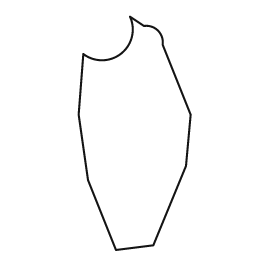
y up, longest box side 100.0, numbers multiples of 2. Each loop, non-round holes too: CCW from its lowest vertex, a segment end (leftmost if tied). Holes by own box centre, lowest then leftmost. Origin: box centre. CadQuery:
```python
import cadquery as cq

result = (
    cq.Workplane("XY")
    .moveTo(-8.0, -50.0)
    .lineTo(8.0, -48.0)
    .lineTo(22.0, -14.0)
    .lineTo(24.0, 8.0)
    .lineTo(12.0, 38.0)
    .threePointArc((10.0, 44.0), (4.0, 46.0))
    .lineTo(-2.0, 50.0)
    .threePointArc((-6.0, 34.0), (-22.0, 34.0))
    .lineTo(-24.0, 8.0)
    .lineTo(-20.0, -20.0)
    .close()
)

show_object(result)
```